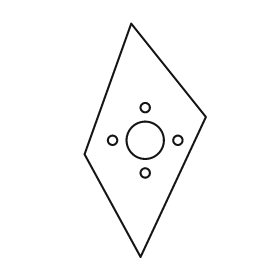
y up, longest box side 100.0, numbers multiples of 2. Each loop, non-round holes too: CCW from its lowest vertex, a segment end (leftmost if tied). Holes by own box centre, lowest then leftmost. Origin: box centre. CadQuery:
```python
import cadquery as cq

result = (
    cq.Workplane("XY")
    .moveTo(-2.0, -50.0)
    .lineTo(26.0, 10.0)
    .lineTo(-6.0, 50.0)
    .lineTo(-26.0, -6.0)
    .close()
    .moveTo(0.0, -14.0)
    .circle(2.0)
    .moveTo(-14.0, 0.0)
    .circle(2.0)
    .moveTo(0.0, 0.0)
    .circle(8.0)
    .moveTo(14.0, 0.0)
    .circle(2.0)
    .moveTo(0.0, 14.0)
    .circle(2.0)
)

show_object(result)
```